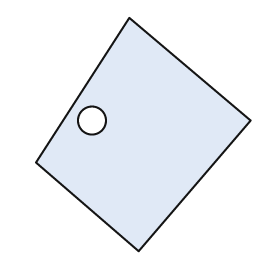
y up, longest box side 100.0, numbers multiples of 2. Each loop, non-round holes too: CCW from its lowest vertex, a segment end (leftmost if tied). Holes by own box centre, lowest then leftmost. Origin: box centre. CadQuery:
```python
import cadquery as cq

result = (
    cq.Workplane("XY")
    .moveTo(-2.0, -50.0)
    .lineTo(46.0, 6.0)
    .lineTo(-6.0, 50.0)
    .lineTo(-46.0, -12.0)
    .close()
    .moveTo(-22.0, 6.0)
    .circle(6.0)
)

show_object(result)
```